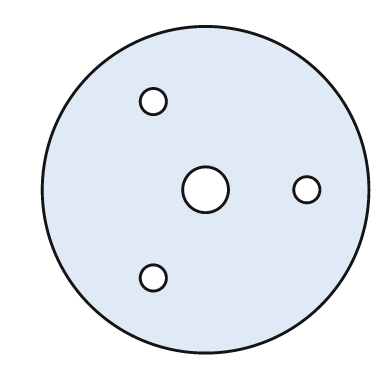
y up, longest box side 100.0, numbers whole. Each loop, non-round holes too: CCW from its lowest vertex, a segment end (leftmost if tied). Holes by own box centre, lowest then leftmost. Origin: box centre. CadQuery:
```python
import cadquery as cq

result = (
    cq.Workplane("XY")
    .moveTo(0.0, 0.0)
    .circle(50.0)
    .moveTo(-16.0, -27.0)
    .circle(4.0)
    .moveTo(0.0, 0.0)
    .circle(7.0)
    .moveTo(31.0, 0.0)
    .circle(4.0)
    .moveTo(-16.0, 27.0)
    .circle(4.0)
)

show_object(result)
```